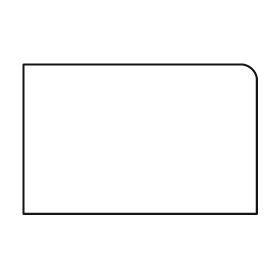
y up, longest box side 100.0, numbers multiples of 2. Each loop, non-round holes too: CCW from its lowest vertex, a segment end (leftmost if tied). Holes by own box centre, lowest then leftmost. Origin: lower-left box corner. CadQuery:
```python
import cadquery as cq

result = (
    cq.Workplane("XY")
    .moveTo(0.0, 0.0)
    .lineTo(100.0, 0.0)
    .lineTo(100.0, 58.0)
    .threePointArc((98.0, 62.0), (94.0, 64.0))
    .lineTo(0.0, 64.0)
    .close()
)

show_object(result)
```